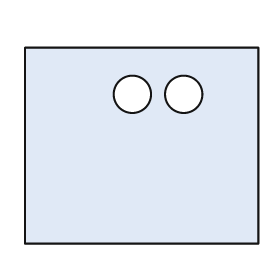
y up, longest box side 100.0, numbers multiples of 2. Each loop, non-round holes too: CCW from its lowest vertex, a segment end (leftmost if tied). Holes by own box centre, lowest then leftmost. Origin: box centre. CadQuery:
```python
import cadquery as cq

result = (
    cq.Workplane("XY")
    .moveTo(-50.0, -42.0)
    .lineTo(50.0, -42.0)
    .lineTo(50.0, 42.0)
    .lineTo(-50.0, 42.0)
    .close()
    .moveTo(-4.0, 22.0)
    .circle(8.0)
    .moveTo(18.0, 22.0)
    .circle(8.0)
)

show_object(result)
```